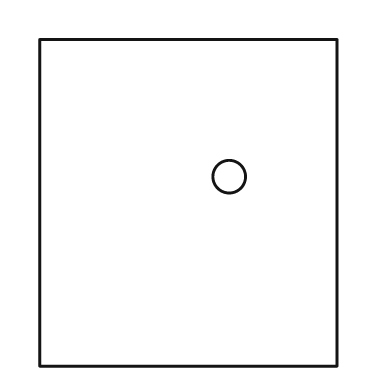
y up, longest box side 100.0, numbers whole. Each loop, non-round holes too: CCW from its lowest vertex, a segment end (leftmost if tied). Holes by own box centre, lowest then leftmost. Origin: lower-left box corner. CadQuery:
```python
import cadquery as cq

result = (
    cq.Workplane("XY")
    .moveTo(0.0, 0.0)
    .lineTo(91.0, 0.0)
    .lineTo(91.0, 100.0)
    .lineTo(0.0, 100.0)
    .close()
    .moveTo(58.0, 58.0)
    .circle(5.0)
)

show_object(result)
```